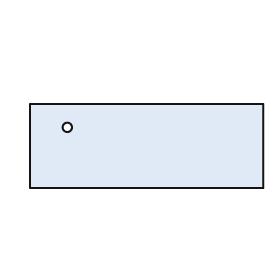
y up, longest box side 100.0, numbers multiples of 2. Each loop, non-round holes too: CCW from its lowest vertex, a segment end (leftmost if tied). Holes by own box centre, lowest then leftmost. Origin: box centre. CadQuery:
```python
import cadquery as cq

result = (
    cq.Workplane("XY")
    .moveTo(-50.0, -18.0)
    .lineTo(50.0, -18.0)
    .lineTo(50.0, 18.0)
    .lineTo(-50.0, 18.0)
    .close()
    .moveTo(-34.0, 8.0)
    .circle(2.0)
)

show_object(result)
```